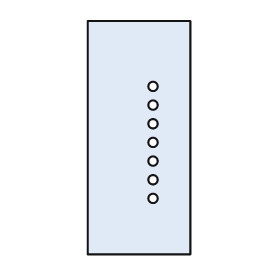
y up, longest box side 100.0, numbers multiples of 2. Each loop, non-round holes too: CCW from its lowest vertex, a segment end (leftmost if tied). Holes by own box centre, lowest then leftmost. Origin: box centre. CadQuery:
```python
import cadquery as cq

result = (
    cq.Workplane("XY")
    .moveTo(-22.0, -50.0)
    .lineTo(22.0, -50.0)
    .lineTo(22.0, 50.0)
    .lineTo(-22.0, 50.0)
    .close()
    .moveTo(6.0, -26.0)
    .circle(2.0)
    .moveTo(6.0, -18.0)
    .circle(2.0)
    .moveTo(6.0, -10.0)
    .circle(2.0)
    .moveTo(6.0, -2.0)
    .circle(2.0)
    .moveTo(6.0, 6.0)
    .circle(2.0)
    .moveTo(6.0, 14.0)
    .circle(2.0)
    .moveTo(6.0, 22.0)
    .circle(2.0)
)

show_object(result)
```